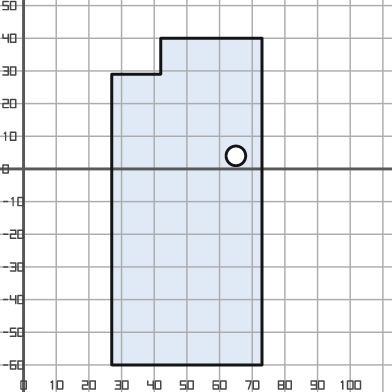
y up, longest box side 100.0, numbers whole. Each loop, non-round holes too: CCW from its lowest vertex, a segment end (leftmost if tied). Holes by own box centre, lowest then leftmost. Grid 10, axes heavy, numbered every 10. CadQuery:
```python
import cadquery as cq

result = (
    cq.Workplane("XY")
    .moveTo(27.0, -60.0)
    .lineTo(73.0, -60.0)
    .lineTo(73.0, 40.0)
    .lineTo(42.0, 40.0)
    .lineTo(42.0, 29.0)
    .lineTo(27.0, 29.0)
    .close()
    .moveTo(65.0, 4.0)
    .circle(3.0)
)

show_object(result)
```